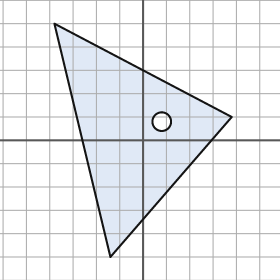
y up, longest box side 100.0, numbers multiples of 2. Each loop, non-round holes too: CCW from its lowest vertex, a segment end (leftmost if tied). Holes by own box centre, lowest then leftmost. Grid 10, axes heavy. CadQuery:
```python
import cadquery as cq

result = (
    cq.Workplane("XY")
    .moveTo(-14.0, -50.0)
    .lineTo(38.0, 10.0)
    .lineTo(-38.0, 50.0)
    .close()
    .moveTo(8.0, 8.0)
    .circle(4.0)
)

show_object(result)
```